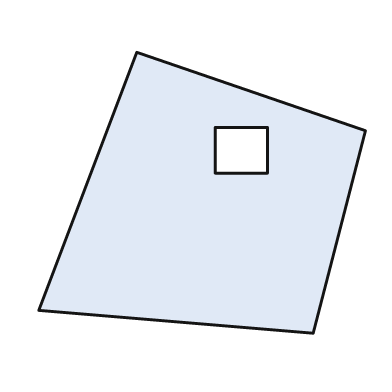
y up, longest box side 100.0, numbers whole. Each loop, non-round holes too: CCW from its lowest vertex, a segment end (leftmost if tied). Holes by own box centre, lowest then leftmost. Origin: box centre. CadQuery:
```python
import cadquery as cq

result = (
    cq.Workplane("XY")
    .moveTo(34.0, -43.0)
    .lineTo(50.0, 19.0)
    .lineTo(-20.0, 43.0)
    .lineTo(-50.0, -36.0)
    .close()
    .moveTo(4.0, 6.0)
    .lineTo(20.0, 6.0)
    .lineTo(20.0, 20.0)
    .lineTo(4.0, 20.0)
    .close()
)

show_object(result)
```